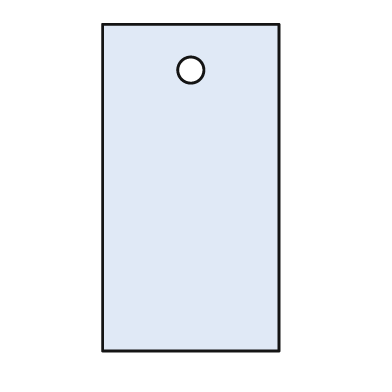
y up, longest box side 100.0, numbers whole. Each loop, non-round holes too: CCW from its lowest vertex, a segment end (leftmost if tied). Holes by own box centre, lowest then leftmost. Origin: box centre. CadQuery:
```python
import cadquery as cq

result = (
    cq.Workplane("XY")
    .moveTo(-27.0, -50.0)
    .lineTo(27.0, -50.0)
    .lineTo(27.0, 50.0)
    .lineTo(-27.0, 50.0)
    .close()
    .moveTo(0.0, 36.0)
    .circle(4.0)
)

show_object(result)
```